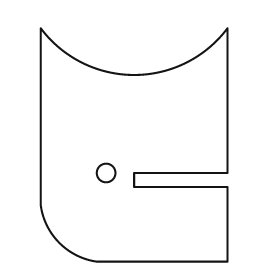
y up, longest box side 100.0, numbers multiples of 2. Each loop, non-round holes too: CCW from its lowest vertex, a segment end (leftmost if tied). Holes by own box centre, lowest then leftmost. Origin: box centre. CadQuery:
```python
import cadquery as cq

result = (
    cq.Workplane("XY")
    .moveTo(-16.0, -50.0)
    .lineTo(40.0, -50.0)
    .lineTo(40.0, -18.0)
    .lineTo(0.0, -18.0)
    .lineTo(0.0, -12.0)
    .lineTo(40.0, -12.0)
    .lineTo(40.0, 50.0)
    .threePointArc((0.0, 30.0), (-40.0, 50.0))
    .lineTo(-40.0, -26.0)
    .threePointArc((-32.0, -42.0), (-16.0, -50.0))
    .close()
    .moveTo(-12.0, -12.0)
    .circle(4.0)
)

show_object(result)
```